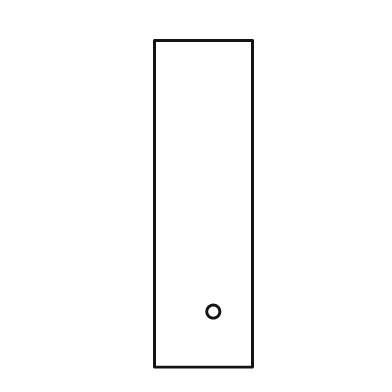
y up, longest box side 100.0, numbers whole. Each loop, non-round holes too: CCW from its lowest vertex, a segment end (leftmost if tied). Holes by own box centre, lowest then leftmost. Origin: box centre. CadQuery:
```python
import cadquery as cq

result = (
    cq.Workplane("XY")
    .moveTo(-15.0, -50.0)
    .lineTo(15.0, -50.0)
    .lineTo(15.0, 50.0)
    .lineTo(-15.0, 50.0)
    .close()
    .moveTo(3.0, -33.0)
    .circle(2.0)
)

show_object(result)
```